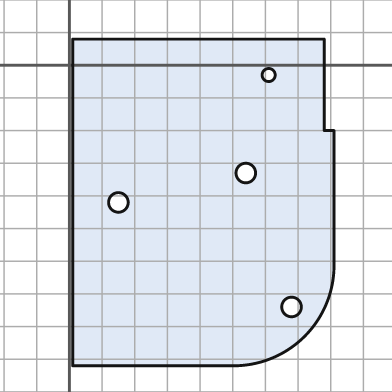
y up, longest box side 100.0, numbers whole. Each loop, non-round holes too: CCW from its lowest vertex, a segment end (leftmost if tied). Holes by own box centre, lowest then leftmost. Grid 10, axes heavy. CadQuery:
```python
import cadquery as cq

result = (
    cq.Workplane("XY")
    .moveTo(1.0, -92.0)
    .lineTo(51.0, -92.0)
    .threePointArc((72.0, -83.0), (81.0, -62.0))
    .lineTo(81.0, -20.0)
    .lineTo(78.0, -20.0)
    .lineTo(78.0, 8.0)
    .lineTo(1.0, 8.0)
    .close()
    .moveTo(68.0, -74.0)
    .circle(3.0)
    .moveTo(15.0, -42.0)
    .circle(3.0)
    .moveTo(54.0, -33.0)
    .circle(3.0)
    .moveTo(61.0, -3.0)
    .circle(2.0)
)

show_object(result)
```